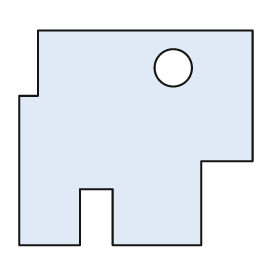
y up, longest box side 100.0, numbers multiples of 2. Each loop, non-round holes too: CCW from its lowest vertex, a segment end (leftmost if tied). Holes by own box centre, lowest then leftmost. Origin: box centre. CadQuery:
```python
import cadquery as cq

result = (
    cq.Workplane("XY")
    .moveTo(-50.0, -46.0)
    .lineTo(-24.0, -46.0)
    .lineTo(-24.0, -22.0)
    .lineTo(-10.0, -22.0)
    .lineTo(-10.0, -46.0)
    .lineTo(28.0, -46.0)
    .lineTo(28.0, -10.0)
    .lineTo(50.0, -10.0)
    .lineTo(50.0, 46.0)
    .lineTo(-42.0, 46.0)
    .lineTo(-42.0, 18.0)
    .lineTo(-50.0, 18.0)
    .close()
    .moveTo(16.0, 30.0)
    .circle(8.0)
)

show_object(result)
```